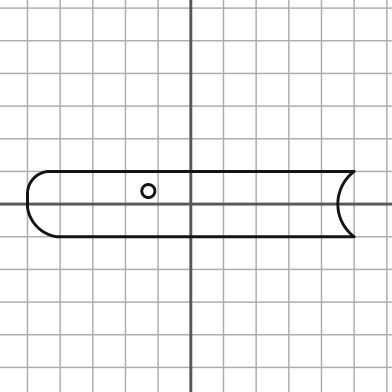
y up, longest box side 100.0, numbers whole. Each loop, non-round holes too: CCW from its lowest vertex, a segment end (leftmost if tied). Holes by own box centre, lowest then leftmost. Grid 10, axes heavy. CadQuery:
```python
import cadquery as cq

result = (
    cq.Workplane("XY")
    .moveTo(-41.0, -10.0)
    .lineTo(50.0, -10.0)
    .threePointArc((45.0, 0.0), (50.0, 10.0))
    .lineTo(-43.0, 10.0)
    .threePointArc((-48.0, 8.0), (-50.0, 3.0))
    .lineTo(-50.0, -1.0)
    .threePointArc((-47.0, -7.0), (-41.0, -10.0))
    .close()
    .moveTo(-13.0, 4.0)
    .circle(2.0)
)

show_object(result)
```